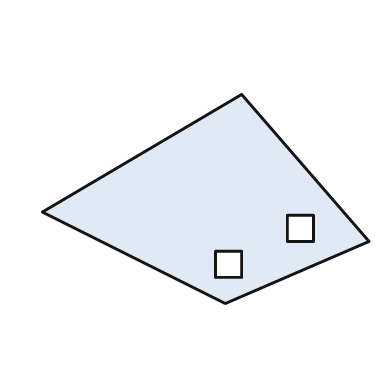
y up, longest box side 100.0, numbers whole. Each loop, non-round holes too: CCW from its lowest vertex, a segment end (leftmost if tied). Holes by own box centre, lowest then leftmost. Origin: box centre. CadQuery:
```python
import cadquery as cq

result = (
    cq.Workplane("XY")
    .moveTo(6.0, -32.0)
    .lineTo(50.0, -13.0)
    .lineTo(11.0, 32.0)
    .lineTo(-50.0, -4.0)
    .close()
    .moveTo(3.0, -24.0)
    .lineTo(11.0, -24.0)
    .lineTo(11.0, -16.0)
    .lineTo(3.0, -16.0)
    .close()
    .moveTo(25.0, -13.0)
    .lineTo(33.0, -13.0)
    .lineTo(33.0, -5.0)
    .lineTo(25.0, -5.0)
    .close()
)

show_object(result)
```